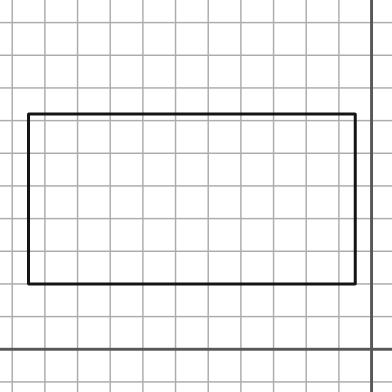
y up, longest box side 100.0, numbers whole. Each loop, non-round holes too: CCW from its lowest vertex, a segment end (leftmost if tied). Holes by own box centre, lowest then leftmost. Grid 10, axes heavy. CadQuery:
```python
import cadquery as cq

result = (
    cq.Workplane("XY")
    .moveTo(-105.0, 20.0)
    .lineTo(-5.0, 20.0)
    .lineTo(-5.0, 72.0)
    .lineTo(-105.0, 72.0)
    .close()
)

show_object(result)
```